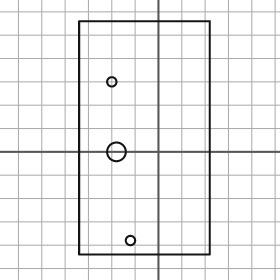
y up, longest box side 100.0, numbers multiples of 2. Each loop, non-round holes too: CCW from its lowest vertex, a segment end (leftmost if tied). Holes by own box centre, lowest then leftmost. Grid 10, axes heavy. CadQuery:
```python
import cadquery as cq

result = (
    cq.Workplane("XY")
    .moveTo(-34.0, -44.0)
    .lineTo(22.0, -44.0)
    .lineTo(22.0, 56.0)
    .lineTo(-34.0, 56.0)
    .close()
    .moveTo(-12.0, -38.0)
    .circle(2.0)
    .moveTo(-18.0, 0.0)
    .circle(4.0)
    .moveTo(-20.0, 30.0)
    .circle(2.0)
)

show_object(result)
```